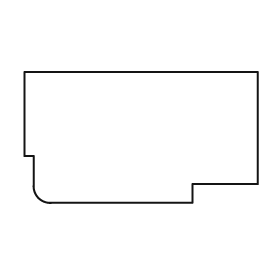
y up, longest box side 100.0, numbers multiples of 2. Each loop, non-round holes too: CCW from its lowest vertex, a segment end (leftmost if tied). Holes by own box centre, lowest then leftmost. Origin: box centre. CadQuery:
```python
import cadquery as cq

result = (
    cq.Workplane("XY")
    .moveTo(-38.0, -28.0)
    .lineTo(22.0, -28.0)
    .lineTo(22.0, -20.0)
    .lineTo(50.0, -20.0)
    .lineTo(50.0, 28.0)
    .lineTo(-50.0, 28.0)
    .lineTo(-50.0, -8.0)
    .lineTo(-46.0, -8.0)
    .lineTo(-46.0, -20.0)
    .threePointArc((-44.0, -26.0), (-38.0, -28.0))
    .close()
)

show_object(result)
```